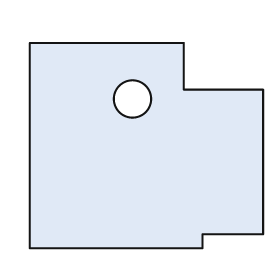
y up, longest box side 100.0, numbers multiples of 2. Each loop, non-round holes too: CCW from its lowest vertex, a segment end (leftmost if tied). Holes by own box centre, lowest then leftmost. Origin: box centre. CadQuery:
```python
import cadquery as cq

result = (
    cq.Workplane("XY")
    .moveTo(-50.0, -44.0)
    .lineTo(24.0, -44.0)
    .lineTo(24.0, -38.0)
    .lineTo(50.0, -38.0)
    .lineTo(50.0, 24.0)
    .lineTo(16.0, 24.0)
    .lineTo(16.0, 44.0)
    .lineTo(-50.0, 44.0)
    .close()
    .moveTo(-6.0, 20.0)
    .circle(8.0)
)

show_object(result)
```